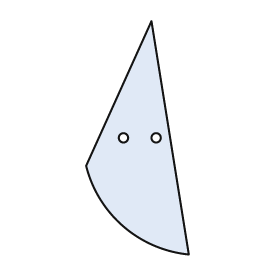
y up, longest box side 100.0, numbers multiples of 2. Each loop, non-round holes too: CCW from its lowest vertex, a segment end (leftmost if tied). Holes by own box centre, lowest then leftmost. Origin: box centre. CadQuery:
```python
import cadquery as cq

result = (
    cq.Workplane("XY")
    .moveTo(22.0, -50.0)
    .lineTo(6.0, 50.0)
    .lineTo(-22.0, -12.0)
    .threePointArc((-6.0, -38.0), (22.0, -50.0))
    .close()
    .moveTo(-6.0, 0.0)
    .circle(2.0)
    .moveTo(8.0, 0.0)
    .circle(2.0)
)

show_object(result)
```